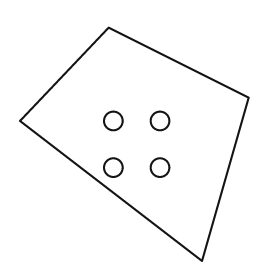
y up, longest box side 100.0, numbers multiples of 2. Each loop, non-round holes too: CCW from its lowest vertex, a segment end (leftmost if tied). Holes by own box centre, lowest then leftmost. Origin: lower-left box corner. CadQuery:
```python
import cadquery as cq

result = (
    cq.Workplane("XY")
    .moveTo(78.0, 0.0)
    .lineTo(98.0, 70.0)
    .lineTo(38.0, 100.0)
    .lineTo(0.0, 60.0)
    .close()
    .moveTo(40.0, 40.0)
    .circle(4.0)
    .moveTo(60.0, 40.0)
    .circle(4.0)
    .moveTo(40.0, 60.0)
    .circle(4.0)
    .moveTo(60.0, 60.0)
    .circle(4.0)
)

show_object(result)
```